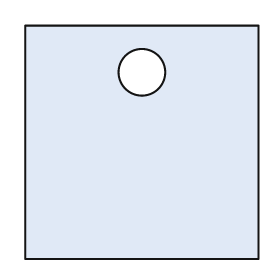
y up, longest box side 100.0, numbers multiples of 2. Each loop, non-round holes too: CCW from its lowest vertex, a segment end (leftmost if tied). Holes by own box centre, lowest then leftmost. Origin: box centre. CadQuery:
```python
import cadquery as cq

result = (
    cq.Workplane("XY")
    .moveTo(-50.0, -50.0)
    .lineTo(50.0, -50.0)
    .lineTo(50.0, 50.0)
    .lineTo(-50.0, 50.0)
    .close()
    .moveTo(0.0, 30.0)
    .circle(10.0)
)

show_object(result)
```